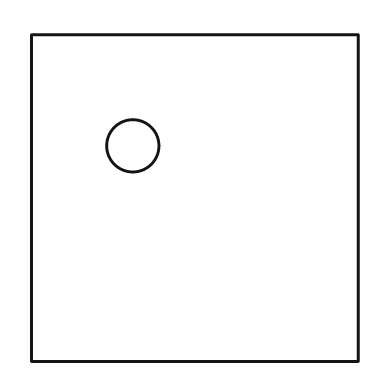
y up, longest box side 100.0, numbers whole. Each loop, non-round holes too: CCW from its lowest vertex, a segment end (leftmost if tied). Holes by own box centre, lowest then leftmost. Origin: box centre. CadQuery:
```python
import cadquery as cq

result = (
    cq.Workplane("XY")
    .moveTo(-50.0, -50.0)
    .lineTo(50.0, -50.0)
    .lineTo(50.0, 50.0)
    .lineTo(-50.0, 50.0)
    .close()
    .moveTo(-19.0, 16.0)
    .circle(8.0)
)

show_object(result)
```